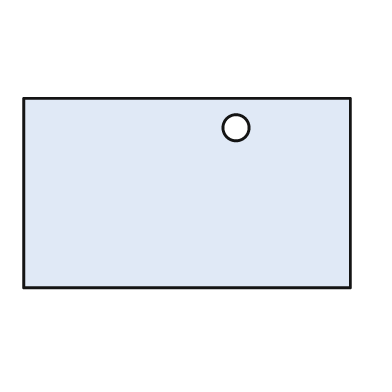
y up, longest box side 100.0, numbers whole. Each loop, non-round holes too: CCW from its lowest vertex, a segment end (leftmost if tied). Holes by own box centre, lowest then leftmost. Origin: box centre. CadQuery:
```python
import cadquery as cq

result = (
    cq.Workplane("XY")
    .moveTo(-50.0, -29.0)
    .lineTo(50.0, -29.0)
    .lineTo(50.0, 29.0)
    .lineTo(-50.0, 29.0)
    .close()
    .moveTo(15.0, 20.0)
    .circle(4.0)
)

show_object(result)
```